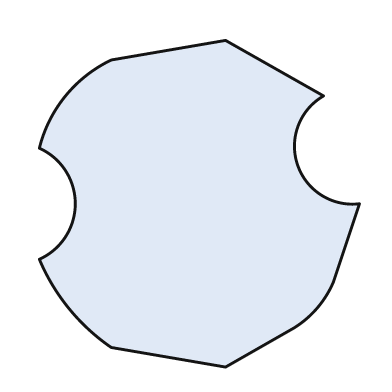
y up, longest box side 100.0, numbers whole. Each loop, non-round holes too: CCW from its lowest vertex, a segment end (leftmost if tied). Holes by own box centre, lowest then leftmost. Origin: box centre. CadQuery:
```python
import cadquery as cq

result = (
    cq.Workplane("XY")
    .moveTo(8.0, -50.0)
    .lineTo(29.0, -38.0)
    .threePointArc((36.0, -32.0), (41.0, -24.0))
    .lineTo(49.0, 0.0)
    .threePointArc((30.0, 12.0), (38.0, 33.0))
    .lineTo(8.0, 50.0)
    .lineTo(-27.0, 44.0)
    .threePointArc((-41.0, 33.0), (-49.0, 17.0))
    .threePointArc((-38.0, 0.0), (-49.0, -17.0))
    .threePointArc((-40.0, -32.0), (-27.0, -44.0))
    .close()
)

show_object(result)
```